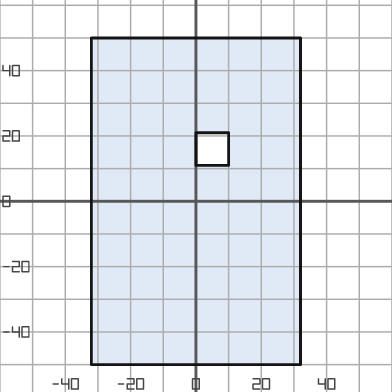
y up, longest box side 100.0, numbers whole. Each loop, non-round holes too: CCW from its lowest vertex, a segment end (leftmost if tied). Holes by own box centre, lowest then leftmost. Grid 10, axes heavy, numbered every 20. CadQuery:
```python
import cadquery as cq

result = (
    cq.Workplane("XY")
    .moveTo(-32.0, -50.0)
    .lineTo(32.0, -50.0)
    .lineTo(32.0, 50.0)
    .lineTo(-32.0, 50.0)
    .close()
    .moveTo(0.0, 11.0)
    .lineTo(10.0, 11.0)
    .lineTo(10.0, 21.0)
    .lineTo(0.0, 21.0)
    .close()
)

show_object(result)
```